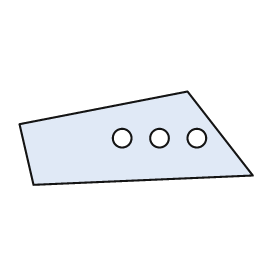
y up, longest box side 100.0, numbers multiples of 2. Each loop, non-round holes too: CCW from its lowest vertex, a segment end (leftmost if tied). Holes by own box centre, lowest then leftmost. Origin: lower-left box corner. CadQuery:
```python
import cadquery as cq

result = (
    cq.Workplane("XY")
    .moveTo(6.0, 0.0)
    .lineTo(100.0, 4.0)
    .lineTo(72.0, 40.0)
    .lineTo(0.0, 26.0)
    .close()
    .moveTo(44.0, 20.0)
    .circle(4.0)
    .moveTo(60.0, 20.0)
    .circle(4.0)
    .moveTo(76.0, 20.0)
    .circle(4.0)
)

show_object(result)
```